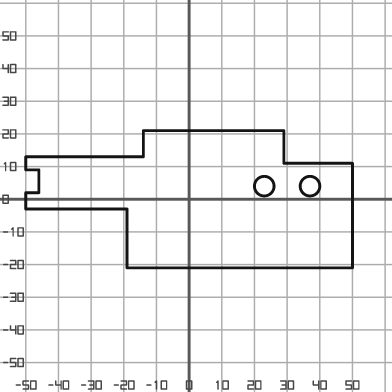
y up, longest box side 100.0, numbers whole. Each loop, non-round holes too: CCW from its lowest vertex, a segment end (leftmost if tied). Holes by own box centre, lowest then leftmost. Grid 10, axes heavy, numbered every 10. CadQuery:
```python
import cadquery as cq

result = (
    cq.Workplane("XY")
    .moveTo(-19.0, -21.0)
    .lineTo(50.0, -21.0)
    .lineTo(50.0, 11.0)
    .lineTo(29.0, 11.0)
    .lineTo(29.0, 21.0)
    .lineTo(-14.0, 21.0)
    .lineTo(-14.0, 13.0)
    .lineTo(-50.0, 13.0)
    .lineTo(-50.0, 9.0)
    .lineTo(-46.0, 9.0)
    .lineTo(-46.0, 2.0)
    .lineTo(-50.0, 2.0)
    .lineTo(-50.0, -3.0)
    .lineTo(-19.0, -3.0)
    .close()
    .moveTo(23.0, 4.0)
    .circle(3.0)
    .moveTo(37.0, 4.0)
    .circle(3.0)
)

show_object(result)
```